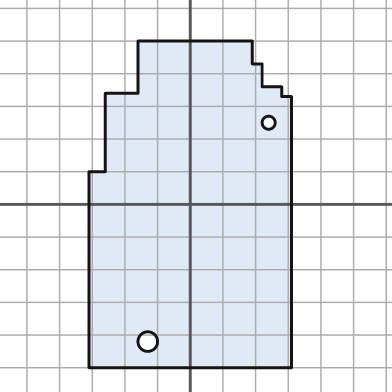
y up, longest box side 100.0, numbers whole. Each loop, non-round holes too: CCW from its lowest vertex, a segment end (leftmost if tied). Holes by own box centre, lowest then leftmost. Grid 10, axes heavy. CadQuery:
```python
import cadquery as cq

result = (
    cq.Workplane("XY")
    .moveTo(-31.0, -50.0)
    .lineTo(31.0, -50.0)
    .lineTo(31.0, 33.0)
    .lineTo(28.0, 33.0)
    .lineTo(28.0, 36.0)
    .lineTo(22.0, 36.0)
    .lineTo(22.0, 43.0)
    .lineTo(19.0, 43.0)
    .lineTo(19.0, 50.0)
    .lineTo(-16.0, 50.0)
    .lineTo(-16.0, 34.0)
    .lineTo(-26.0, 34.0)
    .lineTo(-26.0, 10.0)
    .lineTo(-31.0, 10.0)
    .close()
    .moveTo(-13.0, -42.0)
    .circle(3.0)
    .moveTo(24.0, 25.0)
    .circle(2.0)
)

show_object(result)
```